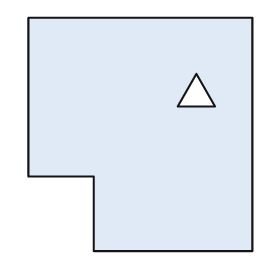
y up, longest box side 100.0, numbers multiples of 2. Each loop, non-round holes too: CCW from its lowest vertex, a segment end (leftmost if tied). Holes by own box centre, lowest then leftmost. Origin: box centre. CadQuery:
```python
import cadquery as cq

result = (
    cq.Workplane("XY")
    .moveTo(-20.0, -50.0)
    .lineTo(48.0, -50.0)
    .lineTo(48.0, 50.0)
    .lineTo(-48.0, 50.0)
    .lineTo(-48.0, -18.0)
    .lineTo(-20.0, -18.0)
    .close()
    .moveTo(16.0, 12.0)
    .lineTo(32.0, 12.0)
    .lineTo(24.0, 26.0)
    .close()
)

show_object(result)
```